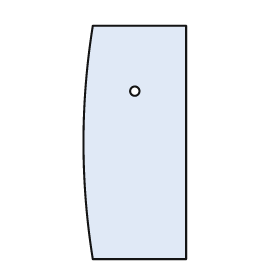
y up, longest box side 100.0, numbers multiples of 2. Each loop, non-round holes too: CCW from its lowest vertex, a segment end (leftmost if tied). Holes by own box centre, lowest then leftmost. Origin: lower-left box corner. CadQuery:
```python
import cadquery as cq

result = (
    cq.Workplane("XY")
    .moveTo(4.0, 0.0)
    .lineTo(44.0, 0.0)
    .lineTo(44.0, 100.0)
    .lineTo(4.0, 100.0)
    .threePointArc((0.0, 50.0), (4.0, 0.0))
    .close()
    .moveTo(22.0, 72.0)
    .circle(2.0)
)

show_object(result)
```